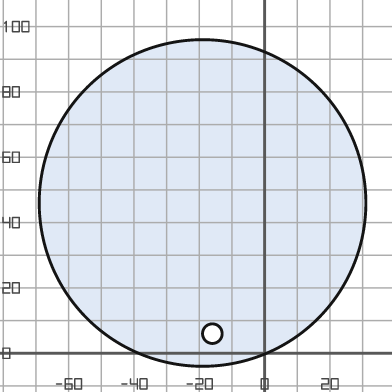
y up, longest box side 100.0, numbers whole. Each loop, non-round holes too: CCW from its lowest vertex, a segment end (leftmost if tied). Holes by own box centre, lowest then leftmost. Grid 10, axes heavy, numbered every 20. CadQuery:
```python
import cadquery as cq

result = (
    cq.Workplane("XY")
    .moveTo(-19.0, 46.0)
    .circle(50.0)
    .moveTo(-16.0, 6.0)
    .circle(3.0)
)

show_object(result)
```